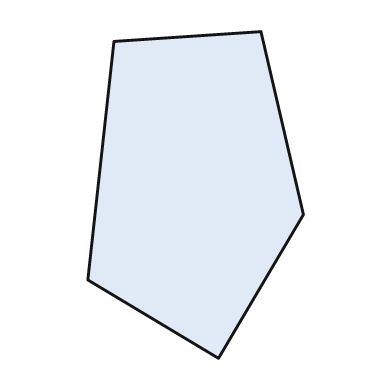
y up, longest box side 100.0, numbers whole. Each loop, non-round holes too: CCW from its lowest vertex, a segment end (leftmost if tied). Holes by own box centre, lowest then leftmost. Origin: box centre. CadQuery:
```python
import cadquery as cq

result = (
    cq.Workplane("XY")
    .moveTo(7.0, -50.0)
    .lineTo(33.0, -6.0)
    .lineTo(20.0, 50.0)
    .lineTo(-25.0, 47.0)
    .lineTo(-33.0, -26.0)
    .close()
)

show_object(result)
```